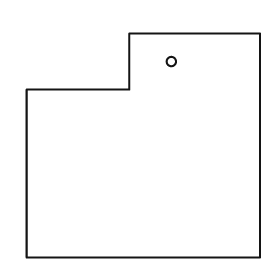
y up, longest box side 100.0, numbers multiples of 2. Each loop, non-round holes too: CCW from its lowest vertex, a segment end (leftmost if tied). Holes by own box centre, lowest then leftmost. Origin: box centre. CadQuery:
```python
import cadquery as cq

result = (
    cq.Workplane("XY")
    .moveTo(-50.0, -48.0)
    .lineTo(50.0, -48.0)
    .lineTo(50.0, 48.0)
    .lineTo(-6.0, 48.0)
    .lineTo(-6.0, 24.0)
    .lineTo(-50.0, 24.0)
    .close()
    .moveTo(12.0, 36.0)
    .circle(2.0)
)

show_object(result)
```